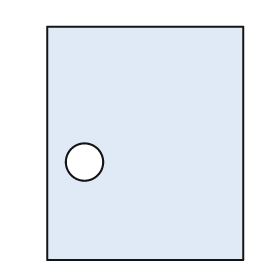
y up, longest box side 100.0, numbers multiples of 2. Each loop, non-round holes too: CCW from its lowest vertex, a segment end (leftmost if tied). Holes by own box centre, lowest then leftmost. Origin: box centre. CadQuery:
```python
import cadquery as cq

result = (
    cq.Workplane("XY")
    .moveTo(-42.0, -50.0)
    .lineTo(42.0, -50.0)
    .lineTo(42.0, 50.0)
    .lineTo(-42.0, 50.0)
    .close()
    .moveTo(-26.0, -8.0)
    .circle(8.0)
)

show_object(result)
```